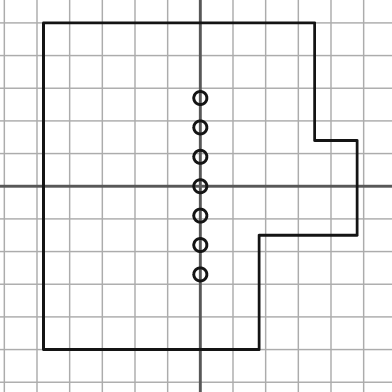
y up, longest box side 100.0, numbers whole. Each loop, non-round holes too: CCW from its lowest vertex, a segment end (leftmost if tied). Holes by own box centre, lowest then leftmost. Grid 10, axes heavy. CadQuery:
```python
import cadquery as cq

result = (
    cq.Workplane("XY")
    .moveTo(-48.0, -50.0)
    .lineTo(18.0, -50.0)
    .lineTo(18.0, -15.0)
    .lineTo(48.0, -15.0)
    .lineTo(48.0, 14.0)
    .lineTo(35.0, 14.0)
    .lineTo(35.0, 50.0)
    .lineTo(-48.0, 50.0)
    .close()
    .moveTo(0.0, -27.0)
    .circle(2.0)
    .moveTo(0.0, -18.0)
    .circle(2.0)
    .moveTo(0.0, -9.0)
    .circle(2.0)
    .moveTo(0.0, 0.0)
    .circle(2.0)
    .moveTo(0.0, 9.0)
    .circle(2.0)
    .moveTo(0.0, 18.0)
    .circle(2.0)
    .moveTo(0.0, 27.0)
    .circle(2.0)
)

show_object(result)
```